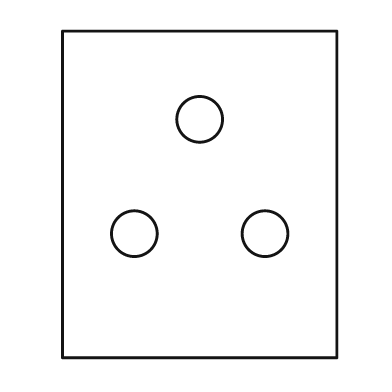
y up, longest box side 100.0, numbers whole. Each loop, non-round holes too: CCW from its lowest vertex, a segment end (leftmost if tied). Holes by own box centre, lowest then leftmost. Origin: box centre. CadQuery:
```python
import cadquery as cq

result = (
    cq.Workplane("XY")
    .moveTo(-42.0, -50.0)
    .lineTo(42.0, -50.0)
    .lineTo(42.0, 50.0)
    .lineTo(-42.0, 50.0)
    .close()
    .moveTo(-20.0, -12.0)
    .circle(7.0)
    .moveTo(20.0, -12.0)
    .circle(7.0)
    .moveTo(0.0, 23.0)
    .circle(7.0)
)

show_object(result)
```